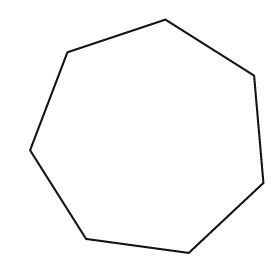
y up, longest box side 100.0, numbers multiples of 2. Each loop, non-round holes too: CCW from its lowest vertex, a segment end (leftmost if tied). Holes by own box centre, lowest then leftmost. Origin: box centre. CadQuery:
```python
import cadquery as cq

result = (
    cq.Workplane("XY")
    .moveTo(18.0, -50.0)
    .lineTo(50.0, -20.0)
    .lineTo(46.0, 26.0)
    .lineTo(8.0, 50.0)
    .lineTo(-34.0, 36.0)
    .lineTo(-50.0, -6.0)
    .lineTo(-26.0, -44.0)
    .close()
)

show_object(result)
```